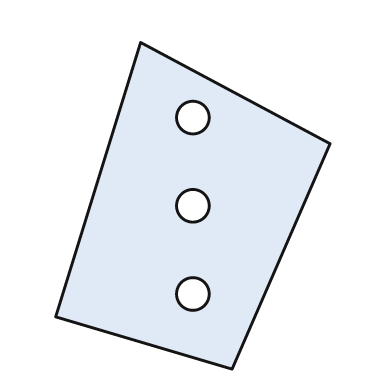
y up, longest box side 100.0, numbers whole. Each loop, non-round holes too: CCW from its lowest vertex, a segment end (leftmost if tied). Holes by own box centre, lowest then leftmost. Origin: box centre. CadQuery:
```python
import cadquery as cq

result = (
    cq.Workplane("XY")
    .moveTo(12.0, -50.0)
    .lineTo(42.0, 19.0)
    .lineTo(-16.0, 50.0)
    .lineTo(-42.0, -34.0)
    .close()
    .moveTo(0.0, -27.0)
    .circle(5.0)
    .moveTo(0.0, 0.0)
    .circle(5.0)
    .moveTo(0.0, 27.0)
    .circle(5.0)
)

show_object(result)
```